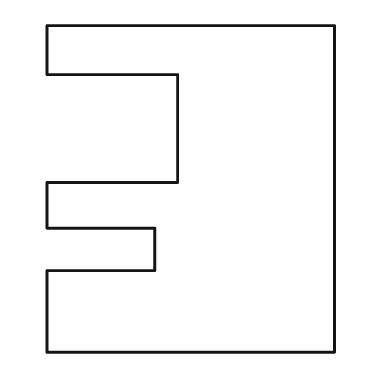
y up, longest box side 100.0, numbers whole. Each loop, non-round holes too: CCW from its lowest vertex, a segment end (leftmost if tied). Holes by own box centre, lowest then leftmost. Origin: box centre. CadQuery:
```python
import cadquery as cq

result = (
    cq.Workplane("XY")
    .moveTo(-44.0, -50.0)
    .lineTo(44.0, -50.0)
    .lineTo(44.0, 50.0)
    .lineTo(-44.0, 50.0)
    .lineTo(-44.0, 35.0)
    .lineTo(-4.0, 35.0)
    .lineTo(-4.0, 2.0)
    .lineTo(-44.0, 2.0)
    .lineTo(-44.0, -12.0)
    .lineTo(-11.0, -12.0)
    .lineTo(-11.0, -25.0)
    .lineTo(-44.0, -25.0)
    .close()
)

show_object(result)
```